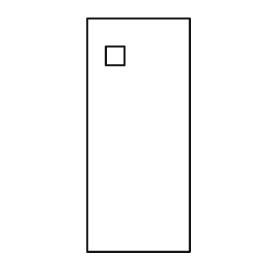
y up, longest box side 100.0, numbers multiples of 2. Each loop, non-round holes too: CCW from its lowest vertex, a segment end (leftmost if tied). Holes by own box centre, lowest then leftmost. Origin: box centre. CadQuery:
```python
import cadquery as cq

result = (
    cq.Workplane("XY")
    .moveTo(-22.0, -50.0)
    .lineTo(22.0, -50.0)
    .lineTo(22.0, 50.0)
    .lineTo(-22.0, 50.0)
    .close()
    .moveTo(-14.0, 30.0)
    .lineTo(-6.0, 30.0)
    .lineTo(-6.0, 38.0)
    .lineTo(-14.0, 38.0)
    .close()
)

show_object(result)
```